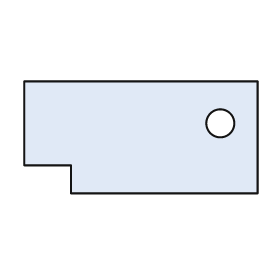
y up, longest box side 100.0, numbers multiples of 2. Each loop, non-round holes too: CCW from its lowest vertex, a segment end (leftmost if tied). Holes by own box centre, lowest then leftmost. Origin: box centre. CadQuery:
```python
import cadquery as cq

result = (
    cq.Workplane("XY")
    .moveTo(-30.0, -24.0)
    .lineTo(50.0, -24.0)
    .lineTo(50.0, 24.0)
    .lineTo(-50.0, 24.0)
    .lineTo(-50.0, -12.0)
    .lineTo(-30.0, -12.0)
    .close()
    .moveTo(34.0, 6.0)
    .circle(6.0)
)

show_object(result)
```